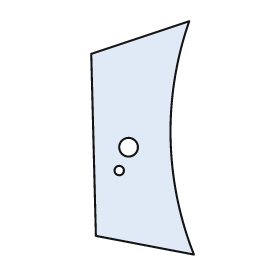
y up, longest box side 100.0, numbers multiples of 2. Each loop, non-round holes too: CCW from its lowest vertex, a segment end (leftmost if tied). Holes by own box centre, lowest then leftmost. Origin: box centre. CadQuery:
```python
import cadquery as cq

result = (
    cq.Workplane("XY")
    .moveTo(22.0, -50.0)
    .threePointArc((12.0, 0.0), (20.0, 50.0))
    .lineTo(-22.0, 36.0)
    .lineTo(-20.0, -42.0)
    .close()
    .moveTo(-10.0, -14.0)
    .circle(2.0)
    .moveTo(-6.0, -4.0)
    .circle(4.0)
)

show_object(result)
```